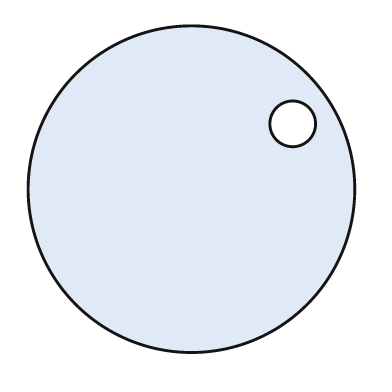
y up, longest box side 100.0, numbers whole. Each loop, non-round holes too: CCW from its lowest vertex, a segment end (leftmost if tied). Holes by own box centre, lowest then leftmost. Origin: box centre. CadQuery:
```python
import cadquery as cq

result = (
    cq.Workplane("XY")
    .moveTo(0.0, 0.0)
    .circle(50.0)
    .moveTo(31.0, 20.0)
    .circle(7.0)
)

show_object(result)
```